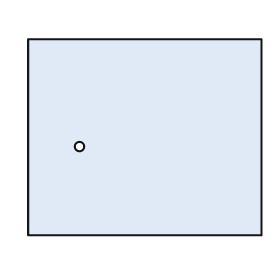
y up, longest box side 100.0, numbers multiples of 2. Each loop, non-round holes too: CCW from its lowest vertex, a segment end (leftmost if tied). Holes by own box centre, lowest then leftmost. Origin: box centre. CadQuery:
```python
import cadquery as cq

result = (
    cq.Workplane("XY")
    .moveTo(-50.0, -42.0)
    .lineTo(50.0, -42.0)
    .lineTo(50.0, 42.0)
    .lineTo(-50.0, 42.0)
    .close()
    .moveTo(-28.0, -4.0)
    .circle(2.0)
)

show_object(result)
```